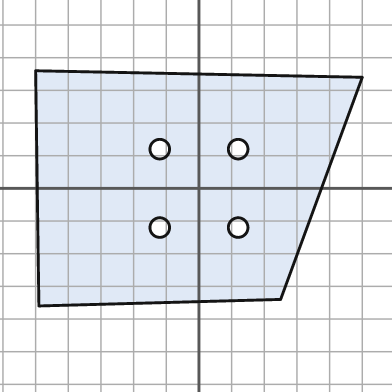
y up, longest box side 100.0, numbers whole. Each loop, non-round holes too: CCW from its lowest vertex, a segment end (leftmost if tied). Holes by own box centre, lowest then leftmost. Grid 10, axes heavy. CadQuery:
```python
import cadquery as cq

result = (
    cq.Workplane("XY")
    .moveTo(-49.0, -36.0)
    .lineTo(25.0, -34.0)
    .lineTo(50.0, 34.0)
    .lineTo(-50.0, 36.0)
    .close()
    .moveTo(-12.0, -12.0)
    .circle(3.0)
    .moveTo(12.0, -12.0)
    .circle(3.0)
    .moveTo(-12.0, 12.0)
    .circle(3.0)
    .moveTo(12.0, 12.0)
    .circle(3.0)
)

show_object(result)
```